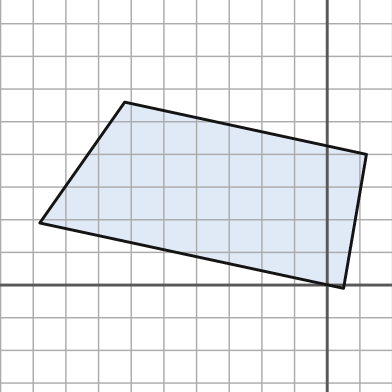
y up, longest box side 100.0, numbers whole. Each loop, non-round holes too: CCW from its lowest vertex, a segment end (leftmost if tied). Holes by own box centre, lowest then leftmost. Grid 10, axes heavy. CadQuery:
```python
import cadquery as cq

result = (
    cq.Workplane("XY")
    .moveTo(5.0, -1.0)
    .lineTo(12.0, 40.0)
    .lineTo(-62.0, 56.0)
    .lineTo(-88.0, 19.0)
    .close()
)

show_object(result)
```